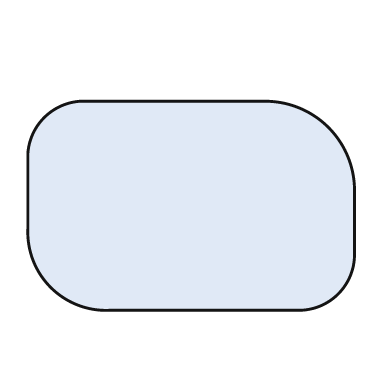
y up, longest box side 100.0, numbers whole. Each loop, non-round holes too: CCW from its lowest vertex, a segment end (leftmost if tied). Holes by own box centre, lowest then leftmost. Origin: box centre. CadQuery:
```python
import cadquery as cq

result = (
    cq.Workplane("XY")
    .moveTo(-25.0, -32.0)
    .lineTo(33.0, -32.0)
    .threePointArc((45.0, -27.0), (50.0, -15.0))
    .lineTo(50.0, 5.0)
    .threePointArc((42.0, 24.0), (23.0, 32.0))
    .lineTo(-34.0, 32.0)
    .threePointArc((-45.0, 27.0), (-50.0, 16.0))
    .lineTo(-50.0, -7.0)
    .threePointArc((-43.0, -25.0), (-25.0, -32.0))
    .close()
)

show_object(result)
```